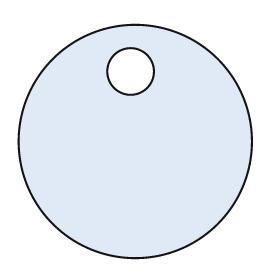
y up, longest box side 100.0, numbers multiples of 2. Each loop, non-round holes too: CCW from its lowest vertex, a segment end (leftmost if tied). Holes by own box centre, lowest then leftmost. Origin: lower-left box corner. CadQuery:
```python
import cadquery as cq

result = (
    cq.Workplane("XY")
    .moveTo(50.0, 50.0)
    .circle(50.0)
    .moveTo(48.0, 80.0)
    .circle(10.0)
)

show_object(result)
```